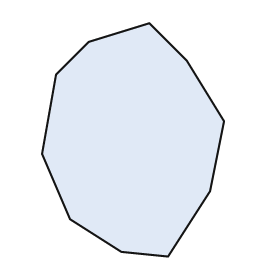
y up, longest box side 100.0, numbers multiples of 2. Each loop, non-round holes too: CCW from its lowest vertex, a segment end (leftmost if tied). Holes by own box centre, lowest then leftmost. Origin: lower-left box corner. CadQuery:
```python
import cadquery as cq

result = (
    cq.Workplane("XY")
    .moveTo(54.0, 0.0)
    .lineTo(72.0, 28.0)
    .lineTo(78.0, 58.0)
    .lineTo(62.0, 84.0)
    .lineTo(46.0, 100.0)
    .lineTo(20.0, 92.0)
    .lineTo(6.0, 78.0)
    .lineTo(0.0, 44.0)
    .lineTo(12.0, 16.0)
    .lineTo(34.0, 2.0)
    .close()
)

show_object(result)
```